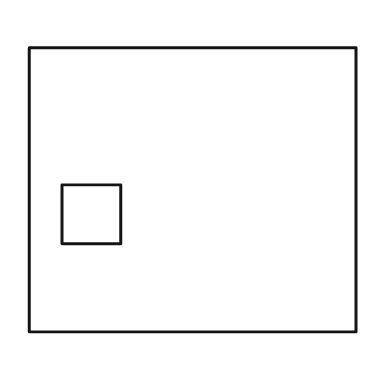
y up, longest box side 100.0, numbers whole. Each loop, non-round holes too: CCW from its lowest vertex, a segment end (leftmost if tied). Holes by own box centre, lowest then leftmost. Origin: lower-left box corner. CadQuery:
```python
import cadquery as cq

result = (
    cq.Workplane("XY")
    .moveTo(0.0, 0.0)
    .lineTo(100.0, 0.0)
    .lineTo(100.0, 87.0)
    .lineTo(0.0, 87.0)
    .close()
    .moveTo(10.0, 27.0)
    .lineTo(28.0, 27.0)
    .lineTo(28.0, 45.0)
    .lineTo(10.0, 45.0)
    .close()
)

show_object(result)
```